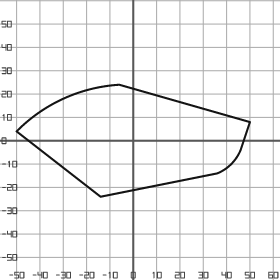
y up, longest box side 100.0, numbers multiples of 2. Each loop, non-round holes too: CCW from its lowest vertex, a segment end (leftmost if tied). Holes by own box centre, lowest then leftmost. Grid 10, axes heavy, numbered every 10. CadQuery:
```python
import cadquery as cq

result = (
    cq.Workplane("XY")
    .moveTo(-14.0, -24.0)
    .lineTo(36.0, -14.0)
    .threePointArc((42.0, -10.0), (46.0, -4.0))
    .lineTo(50.0, 8.0)
    .lineTo(-6.0, 24.0)
    .threePointArc((-30.0, 18.0), (-50.0, 4.0))
    .close()
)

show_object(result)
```